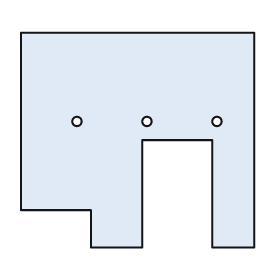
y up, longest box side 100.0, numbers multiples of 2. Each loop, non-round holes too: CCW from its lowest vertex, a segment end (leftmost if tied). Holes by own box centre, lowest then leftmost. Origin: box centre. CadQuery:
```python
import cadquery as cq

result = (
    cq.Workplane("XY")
    .moveTo(-20.0, -46.0)
    .lineTo(2.0, -46.0)
    .lineTo(2.0, 0.0)
    .lineTo(32.0, 0.0)
    .lineTo(32.0, -46.0)
    .lineTo(50.0, -46.0)
    .lineTo(50.0, 46.0)
    .lineTo(-50.0, 46.0)
    .lineTo(-50.0, -30.0)
    .lineTo(-20.0, -30.0)
    .close()
    .moveTo(-26.0, 8.0)
    .circle(2.0)
    .moveTo(4.0, 8.0)
    .circle(2.0)
    .moveTo(34.0, 8.0)
    .circle(2.0)
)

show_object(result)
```